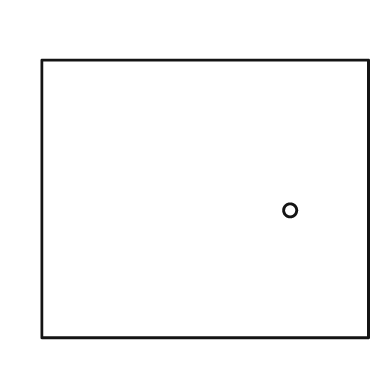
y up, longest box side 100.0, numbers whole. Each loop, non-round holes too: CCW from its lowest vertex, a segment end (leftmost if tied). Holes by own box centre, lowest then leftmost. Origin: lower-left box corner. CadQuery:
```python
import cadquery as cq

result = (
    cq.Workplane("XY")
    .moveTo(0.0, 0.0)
    .lineTo(100.0, 0.0)
    .lineTo(100.0, 85.0)
    .lineTo(0.0, 85.0)
    .close()
    .moveTo(76.0, 39.0)
    .circle(2.0)
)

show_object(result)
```